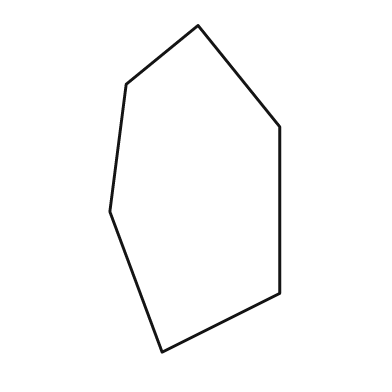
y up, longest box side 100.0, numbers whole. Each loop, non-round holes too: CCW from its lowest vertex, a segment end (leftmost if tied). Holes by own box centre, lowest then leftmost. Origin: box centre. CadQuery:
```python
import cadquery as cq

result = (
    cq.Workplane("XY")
    .moveTo(-10.0, -50.0)
    .lineTo(26.0, -32.0)
    .lineTo(26.0, 19.0)
    .lineTo(1.0, 50.0)
    .lineTo(-21.0, 32.0)
    .lineTo(-26.0, -7.0)
    .close()
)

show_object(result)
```